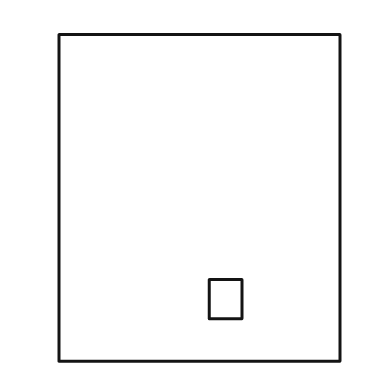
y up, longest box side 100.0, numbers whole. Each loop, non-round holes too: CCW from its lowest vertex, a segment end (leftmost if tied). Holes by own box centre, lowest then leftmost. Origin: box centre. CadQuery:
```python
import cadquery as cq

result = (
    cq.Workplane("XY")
    .moveTo(-43.0, -50.0)
    .lineTo(43.0, -50.0)
    .lineTo(43.0, 50.0)
    .lineTo(-43.0, 50.0)
    .close()
    .moveTo(3.0, -37.0)
    .lineTo(13.0, -37.0)
    .lineTo(13.0, -25.0)
    .lineTo(3.0, -25.0)
    .close()
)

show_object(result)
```